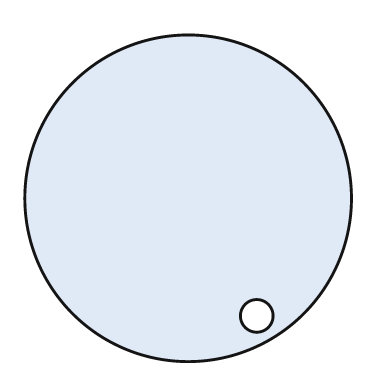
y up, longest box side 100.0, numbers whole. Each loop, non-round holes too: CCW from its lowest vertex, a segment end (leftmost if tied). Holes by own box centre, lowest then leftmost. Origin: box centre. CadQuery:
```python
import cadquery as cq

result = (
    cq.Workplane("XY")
    .moveTo(0.0, 0.0)
    .circle(50.0)
    .moveTo(21.0, -36.0)
    .circle(5.0)
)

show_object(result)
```